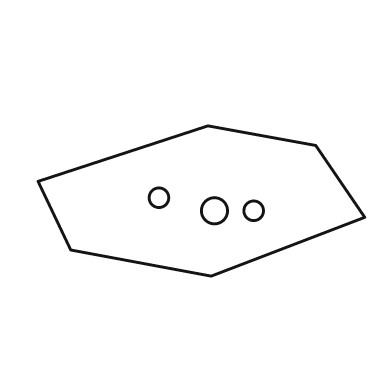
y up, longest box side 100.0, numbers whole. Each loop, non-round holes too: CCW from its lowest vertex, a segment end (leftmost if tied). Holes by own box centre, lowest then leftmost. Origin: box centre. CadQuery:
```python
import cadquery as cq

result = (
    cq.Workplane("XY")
    .moveTo(3.0, -23.0)
    .lineTo(50.0, -5.0)
    .lineTo(35.0, 17.0)
    .lineTo(2.0, 23.0)
    .lineTo(-50.0, 6.0)
    .lineTo(-40.0, -15.0)
    .close()
    .moveTo(4.0, -3.0)
    .circle(4.0)
    .moveTo(16.0, -3.0)
    .circle(3.0)
    .moveTo(-13.0, 1.0)
    .circle(3.0)
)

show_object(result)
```